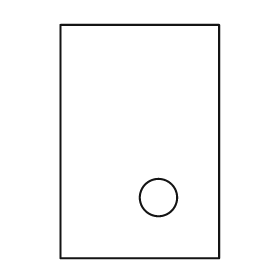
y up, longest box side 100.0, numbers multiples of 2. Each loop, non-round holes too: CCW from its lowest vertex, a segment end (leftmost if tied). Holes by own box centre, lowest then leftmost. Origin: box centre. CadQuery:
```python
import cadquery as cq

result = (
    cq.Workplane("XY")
    .moveTo(-34.0, -50.0)
    .lineTo(34.0, -50.0)
    .lineTo(34.0, 50.0)
    .lineTo(-34.0, 50.0)
    .close()
    .moveTo(8.0, -24.0)
    .circle(8.0)
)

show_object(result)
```